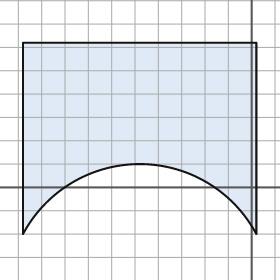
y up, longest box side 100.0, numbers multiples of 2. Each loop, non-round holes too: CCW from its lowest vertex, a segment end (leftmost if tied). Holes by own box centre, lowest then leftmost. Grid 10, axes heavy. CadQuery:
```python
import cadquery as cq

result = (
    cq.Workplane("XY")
    .moveTo(-98.0, -20.0)
    .threePointArc((-48.0, 10.0), (2.0, -20.0))
    .lineTo(2.0, 62.0)
    .lineTo(-98.0, 62.0)
    .close()
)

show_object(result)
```